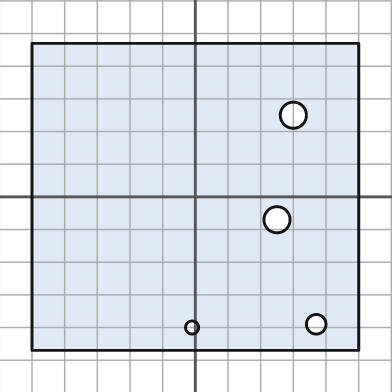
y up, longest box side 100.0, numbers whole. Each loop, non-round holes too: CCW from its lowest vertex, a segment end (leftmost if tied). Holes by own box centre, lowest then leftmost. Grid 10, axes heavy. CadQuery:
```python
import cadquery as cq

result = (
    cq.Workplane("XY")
    .moveTo(-50.0, -47.0)
    .lineTo(50.0, -47.0)
    .lineTo(50.0, 47.0)
    .lineTo(-50.0, 47.0)
    .close()
    .moveTo(-1.0, -40.0)
    .circle(2.0)
    .moveTo(37.0, -39.0)
    .circle(3.0)
    .moveTo(25.0, -7.0)
    .circle(4.0)
    .moveTo(30.0, 25.0)
    .circle(4.0)
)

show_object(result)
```